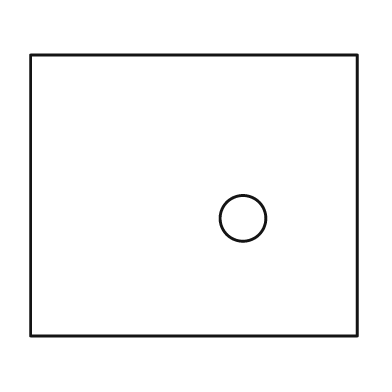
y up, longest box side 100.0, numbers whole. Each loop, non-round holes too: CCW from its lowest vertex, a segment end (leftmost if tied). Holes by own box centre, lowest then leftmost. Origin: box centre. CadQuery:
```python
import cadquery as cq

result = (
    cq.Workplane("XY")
    .moveTo(-50.0, -43.0)
    .lineTo(50.0, -43.0)
    .lineTo(50.0, 43.0)
    .lineTo(-50.0, 43.0)
    .close()
    .moveTo(15.0, -7.0)
    .circle(7.0)
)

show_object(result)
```